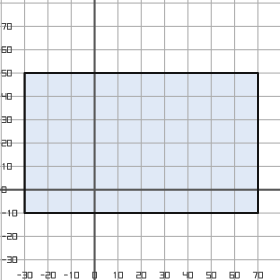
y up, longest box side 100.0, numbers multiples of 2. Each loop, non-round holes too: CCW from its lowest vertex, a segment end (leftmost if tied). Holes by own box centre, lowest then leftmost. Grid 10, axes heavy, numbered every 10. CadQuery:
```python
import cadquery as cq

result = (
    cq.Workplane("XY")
    .moveTo(-30.0, -10.0)
    .lineTo(70.0, -10.0)
    .lineTo(70.0, 50.0)
    .lineTo(-30.0, 50.0)
    .close()
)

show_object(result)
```